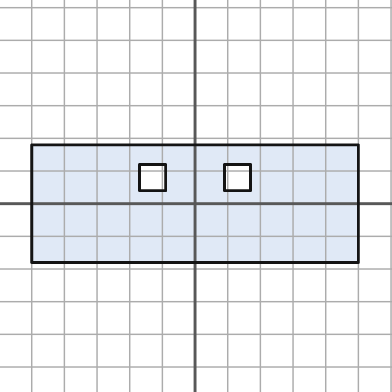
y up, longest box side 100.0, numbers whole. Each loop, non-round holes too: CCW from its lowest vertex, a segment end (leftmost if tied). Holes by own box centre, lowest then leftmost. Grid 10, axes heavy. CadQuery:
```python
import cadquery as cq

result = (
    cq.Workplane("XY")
    .moveTo(-50.0, -18.0)
    .lineTo(50.0, -18.0)
    .lineTo(50.0, 18.0)
    .lineTo(-50.0, 18.0)
    .close()
    .moveTo(-17.0, 4.0)
    .lineTo(-9.0, 4.0)
    .lineTo(-9.0, 12.0)
    .lineTo(-17.0, 12.0)
    .close()
    .moveTo(9.0, 4.0)
    .lineTo(17.0, 4.0)
    .lineTo(17.0, 12.0)
    .lineTo(9.0, 12.0)
    .close()
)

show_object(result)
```